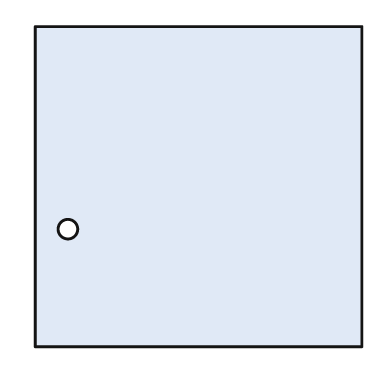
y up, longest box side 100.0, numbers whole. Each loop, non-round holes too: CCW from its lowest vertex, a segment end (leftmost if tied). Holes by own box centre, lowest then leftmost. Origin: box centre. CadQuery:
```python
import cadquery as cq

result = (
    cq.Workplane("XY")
    .moveTo(-50.0, -49.0)
    .lineTo(50.0, -49.0)
    .lineTo(50.0, 49.0)
    .lineTo(-50.0, 49.0)
    .close()
    .moveTo(-40.0, -13.0)
    .circle(3.0)
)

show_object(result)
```